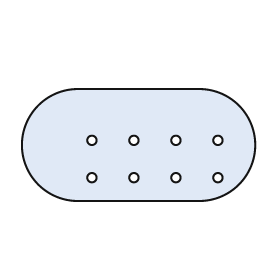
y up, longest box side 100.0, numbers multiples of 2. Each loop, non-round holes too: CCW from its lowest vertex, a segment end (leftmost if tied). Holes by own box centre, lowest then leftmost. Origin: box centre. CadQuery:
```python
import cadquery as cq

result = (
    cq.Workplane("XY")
    .moveTo(-26.0, -24.0)
    .lineTo(26.0, -24.0)
    .threePointArc((50.0, 0.0), (26.0, 24.0))
    .lineTo(-26.0, 24.0)
    .threePointArc((-50.0, 0.0), (-26.0, -24.0))
    .close()
    .moveTo(-20.0, -14.0)
    .circle(2.0)
    .moveTo(-2.0, -14.0)
    .circle(2.0)
    .moveTo(16.0, -14.0)
    .circle(2.0)
    .moveTo(34.0, -14.0)
    .circle(2.0)
    .moveTo(-20.0, 2.0)
    .circle(2.0)
    .moveTo(-2.0, 2.0)
    .circle(2.0)
    .moveTo(16.0, 2.0)
    .circle(2.0)
    .moveTo(34.0, 2.0)
    .circle(2.0)
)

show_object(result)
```